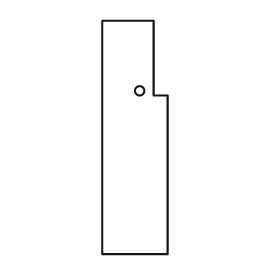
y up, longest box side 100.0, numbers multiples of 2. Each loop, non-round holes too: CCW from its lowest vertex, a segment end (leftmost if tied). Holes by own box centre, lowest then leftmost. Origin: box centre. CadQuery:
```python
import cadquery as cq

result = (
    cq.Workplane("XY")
    .moveTo(-14.0, -50.0)
    .lineTo(14.0, -50.0)
    .lineTo(14.0, 18.0)
    .lineTo(8.0, 18.0)
    .lineTo(8.0, 50.0)
    .lineTo(-14.0, 50.0)
    .close()
    .moveTo(2.0, 20.0)
    .circle(2.0)
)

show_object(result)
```